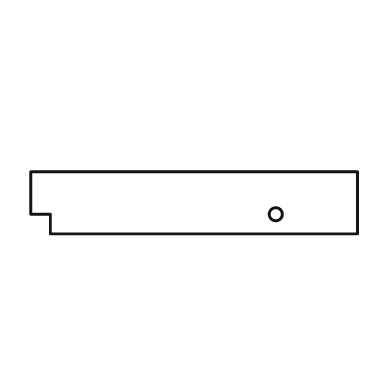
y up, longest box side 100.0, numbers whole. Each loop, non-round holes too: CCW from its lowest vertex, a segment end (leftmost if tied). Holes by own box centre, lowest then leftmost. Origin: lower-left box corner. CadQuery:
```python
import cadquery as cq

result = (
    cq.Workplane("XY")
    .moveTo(6.0, 0.0)
    .lineTo(100.0, 0.0)
    .lineTo(100.0, 19.0)
    .lineTo(0.0, 19.0)
    .lineTo(0.0, 6.0)
    .lineTo(6.0, 6.0)
    .close()
    .moveTo(75.0, 6.0)
    .circle(2.0)
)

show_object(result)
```